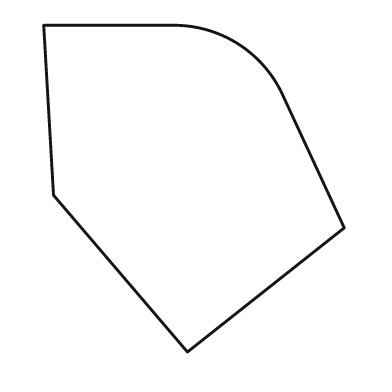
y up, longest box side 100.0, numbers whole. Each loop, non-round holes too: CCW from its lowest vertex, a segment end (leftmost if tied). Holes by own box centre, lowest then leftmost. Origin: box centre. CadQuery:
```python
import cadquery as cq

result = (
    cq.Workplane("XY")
    .moveTo(-2.0, -50.0)
    .lineTo(46.0, -12.0)
    .lineTo(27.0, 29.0)
    .threePointArc((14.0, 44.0), (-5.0, 50.0))
    .lineTo(-46.0, 50.0)
    .lineTo(-43.0, -2.0)
    .close()
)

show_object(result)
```